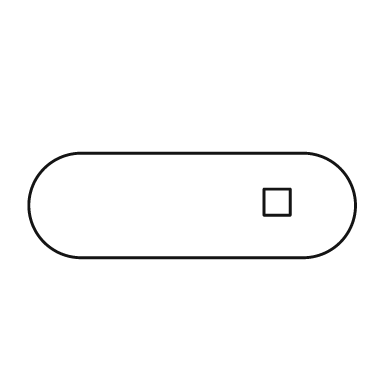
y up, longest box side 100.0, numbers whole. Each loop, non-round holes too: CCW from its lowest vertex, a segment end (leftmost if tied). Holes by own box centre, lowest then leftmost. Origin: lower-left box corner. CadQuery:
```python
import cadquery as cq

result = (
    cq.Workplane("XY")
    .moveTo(16.0, 0.0)
    .lineTo(84.0, 0.0)
    .threePointArc((100.0, 16.0), (84.0, 32.0))
    .lineTo(16.0, 32.0)
    .threePointArc((0.0, 16.0), (16.0, 0.0))
    .close()
    .moveTo(72.0, 13.0)
    .lineTo(80.0, 13.0)
    .lineTo(80.0, 21.0)
    .lineTo(72.0, 21.0)
    .close()
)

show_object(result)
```